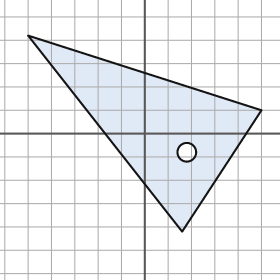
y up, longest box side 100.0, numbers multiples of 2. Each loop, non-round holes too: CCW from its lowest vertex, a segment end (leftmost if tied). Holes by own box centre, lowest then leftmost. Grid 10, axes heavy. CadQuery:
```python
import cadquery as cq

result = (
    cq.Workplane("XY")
    .moveTo(16.0, -42.0)
    .lineTo(50.0, 10.0)
    .lineTo(-50.0, 42.0)
    .close()
    .moveTo(18.0, -8.0)
    .circle(4.0)
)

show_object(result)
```